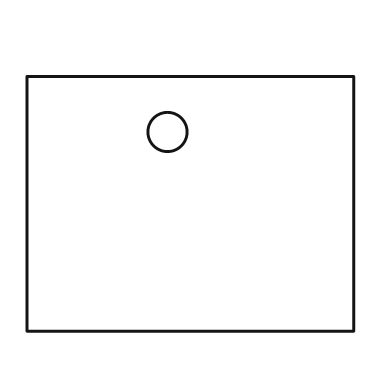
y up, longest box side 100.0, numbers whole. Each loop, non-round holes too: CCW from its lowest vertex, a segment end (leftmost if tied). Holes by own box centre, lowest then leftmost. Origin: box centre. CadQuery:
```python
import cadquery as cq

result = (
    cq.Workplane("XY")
    .moveTo(-50.0, -39.0)
    .lineTo(50.0, -39.0)
    .lineTo(50.0, 39.0)
    .lineTo(-50.0, 39.0)
    .close()
    .moveTo(-7.0, 22.0)
    .circle(6.0)
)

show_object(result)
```